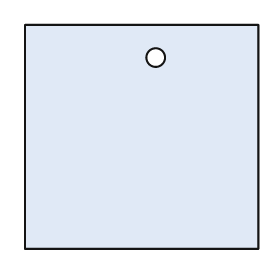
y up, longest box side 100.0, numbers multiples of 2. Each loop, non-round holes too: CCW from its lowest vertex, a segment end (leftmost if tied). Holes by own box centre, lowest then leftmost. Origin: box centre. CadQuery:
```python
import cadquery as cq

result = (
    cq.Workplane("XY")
    .moveTo(-50.0, -48.0)
    .lineTo(50.0, -48.0)
    .lineTo(50.0, 48.0)
    .lineTo(-50.0, 48.0)
    .close()
    .moveTo(6.0, 34.0)
    .circle(4.0)
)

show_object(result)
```